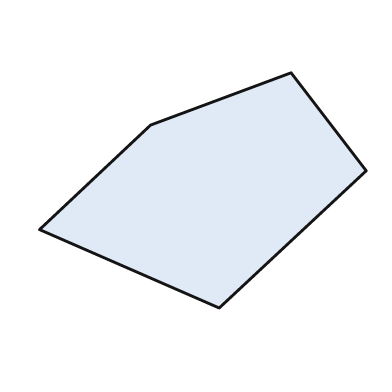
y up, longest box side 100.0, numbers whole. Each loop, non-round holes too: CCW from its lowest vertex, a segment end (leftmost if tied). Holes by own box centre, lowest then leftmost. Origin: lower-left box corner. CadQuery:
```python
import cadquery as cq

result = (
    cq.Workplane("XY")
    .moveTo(55.0, 0.0)
    .lineTo(100.0, 42.0)
    .lineTo(77.0, 72.0)
    .lineTo(34.0, 56.0)
    .lineTo(0.0, 24.0)
    .close()
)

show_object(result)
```